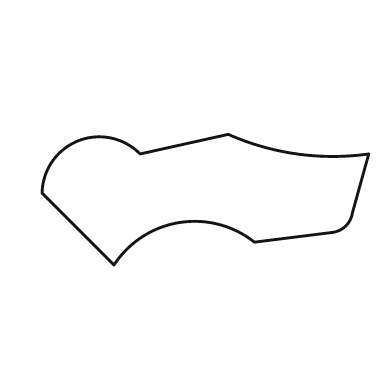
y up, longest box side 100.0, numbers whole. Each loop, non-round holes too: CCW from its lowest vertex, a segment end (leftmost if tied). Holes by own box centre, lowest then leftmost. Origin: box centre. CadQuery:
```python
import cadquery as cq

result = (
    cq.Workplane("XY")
    .moveTo(-28.0, -20.0)
    .threePointArc((-8.0, -7.0), (15.0, -13.0))
    .lineTo(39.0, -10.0)
    .threePointArc((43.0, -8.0), (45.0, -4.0))
    .lineTo(50.0, 14.0)
    .threePointArc((28.0, 14.0), (7.0, 20.0))
    .lineTo(-20.0, 14.0)
    .threePointArc((-39.0, 18.0), (-50.0, 2.0))
    .close()
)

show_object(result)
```